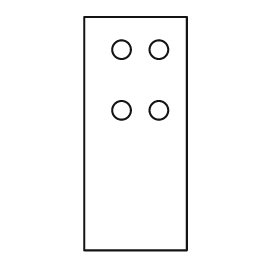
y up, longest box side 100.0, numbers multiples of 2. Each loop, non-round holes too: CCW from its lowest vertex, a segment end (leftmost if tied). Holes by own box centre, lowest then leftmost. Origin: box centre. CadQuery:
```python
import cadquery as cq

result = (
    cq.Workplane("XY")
    .moveTo(-22.0, -50.0)
    .lineTo(22.0, -50.0)
    .lineTo(22.0, 50.0)
    .lineTo(-22.0, 50.0)
    .close()
    .moveTo(-6.0, 10.0)
    .circle(4.0)
    .moveTo(10.0, 10.0)
    .circle(4.0)
    .moveTo(-6.0, 36.0)
    .circle(4.0)
    .moveTo(10.0, 36.0)
    .circle(4.0)
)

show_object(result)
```